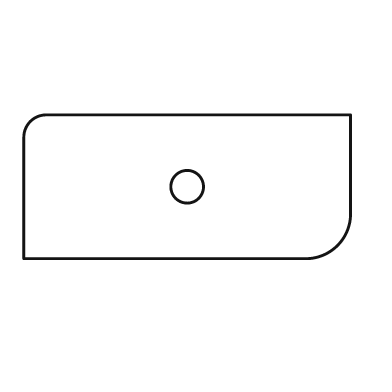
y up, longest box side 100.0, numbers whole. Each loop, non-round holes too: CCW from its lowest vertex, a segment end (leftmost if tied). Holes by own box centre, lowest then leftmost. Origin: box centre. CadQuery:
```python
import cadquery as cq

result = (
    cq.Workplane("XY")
    .moveTo(-50.0, -22.0)
    .lineTo(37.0, -22.0)
    .threePointArc((46.0, -18.0), (50.0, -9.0))
    .lineTo(50.0, 22.0)
    .lineTo(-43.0, 22.0)
    .threePointArc((-48.0, 20.0), (-50.0, 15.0))
    .close()
    .moveTo(0.0, 0.0)
    .circle(5.0)
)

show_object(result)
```